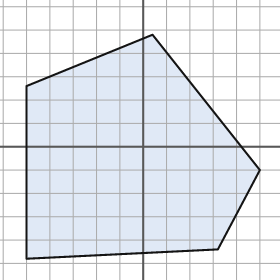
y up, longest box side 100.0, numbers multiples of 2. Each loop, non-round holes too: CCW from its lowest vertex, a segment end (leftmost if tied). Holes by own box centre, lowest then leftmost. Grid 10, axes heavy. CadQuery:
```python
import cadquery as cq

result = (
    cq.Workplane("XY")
    .moveTo(-50.0, -48.0)
    .lineTo(32.0, -44.0)
    .lineTo(50.0, -10.0)
    .lineTo(4.0, 48.0)
    .lineTo(-50.0, 26.0)
    .close()
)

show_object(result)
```